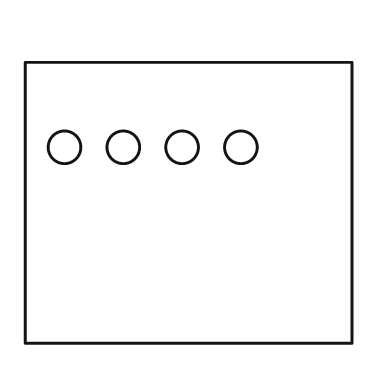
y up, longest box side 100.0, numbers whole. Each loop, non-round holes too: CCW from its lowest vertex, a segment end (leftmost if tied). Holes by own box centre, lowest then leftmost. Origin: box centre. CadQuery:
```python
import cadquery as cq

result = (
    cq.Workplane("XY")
    .moveTo(-50.0, -43.0)
    .lineTo(50.0, -43.0)
    .lineTo(50.0, 43.0)
    .lineTo(-50.0, 43.0)
    .close()
    .moveTo(-38.0, 17.0)
    .circle(5.0)
    .moveTo(-20.0, 17.0)
    .circle(5.0)
    .moveTo(-2.0, 17.0)
    .circle(5.0)
    .moveTo(16.0, 17.0)
    .circle(5.0)
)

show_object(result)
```